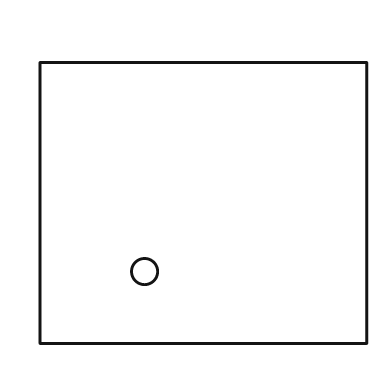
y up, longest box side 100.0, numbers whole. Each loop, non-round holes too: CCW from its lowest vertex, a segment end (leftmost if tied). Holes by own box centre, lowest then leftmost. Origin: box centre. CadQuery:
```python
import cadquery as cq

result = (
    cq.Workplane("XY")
    .moveTo(-50.0, -43.0)
    .lineTo(50.0, -43.0)
    .lineTo(50.0, 43.0)
    .lineTo(-50.0, 43.0)
    .close()
    .moveTo(-18.0, -21.0)
    .circle(4.0)
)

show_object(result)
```